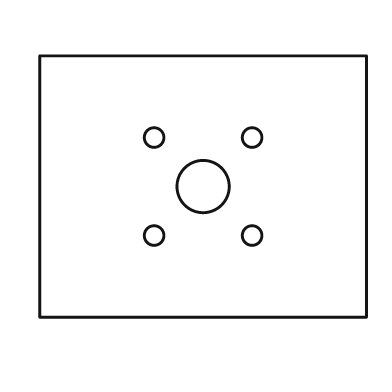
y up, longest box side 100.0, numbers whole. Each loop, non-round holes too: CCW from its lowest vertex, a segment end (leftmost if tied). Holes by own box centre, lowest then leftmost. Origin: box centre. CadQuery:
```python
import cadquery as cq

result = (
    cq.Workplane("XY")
    .moveTo(-50.0, -40.0)
    .lineTo(50.0, -40.0)
    .lineTo(50.0, 40.0)
    .lineTo(-50.0, 40.0)
    .close()
    .moveTo(-15.0, -15.0)
    .circle(3.0)
    .moveTo(15.0, -15.0)
    .circle(3.0)
    .moveTo(0.0, 0.0)
    .circle(8.0)
    .moveTo(-15.0, 15.0)
    .circle(3.0)
    .moveTo(15.0, 15.0)
    .circle(3.0)
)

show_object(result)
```